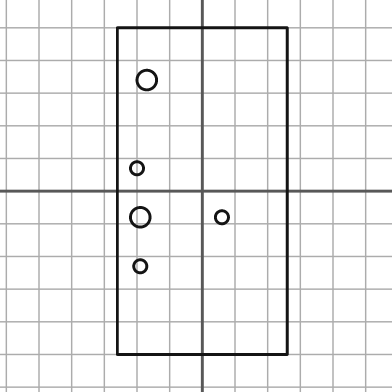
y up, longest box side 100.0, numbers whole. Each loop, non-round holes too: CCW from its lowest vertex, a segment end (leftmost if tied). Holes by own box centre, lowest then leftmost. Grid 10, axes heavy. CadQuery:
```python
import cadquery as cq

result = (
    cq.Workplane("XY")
    .moveTo(-26.0, -50.0)
    .lineTo(26.0, -50.0)
    .lineTo(26.0, 50.0)
    .lineTo(-26.0, 50.0)
    .close()
    .moveTo(-19.0, -23.0)
    .circle(2.0)
    .moveTo(-19.0, -8.0)
    .circle(3.0)
    .moveTo(6.0, -8.0)
    .circle(2.0)
    .moveTo(-20.0, 7.0)
    .circle(2.0)
    .moveTo(-17.0, 34.0)
    .circle(3.0)
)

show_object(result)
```